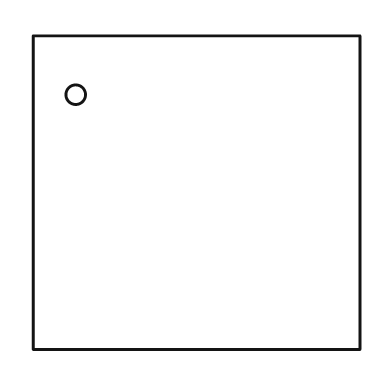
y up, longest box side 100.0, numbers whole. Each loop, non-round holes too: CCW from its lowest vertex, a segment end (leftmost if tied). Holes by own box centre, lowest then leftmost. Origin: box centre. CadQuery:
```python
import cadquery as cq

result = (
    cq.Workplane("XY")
    .moveTo(-50.0, -48.0)
    .lineTo(50.0, -48.0)
    .lineTo(50.0, 48.0)
    .lineTo(-50.0, 48.0)
    .close()
    .moveTo(-37.0, 30.0)
    .circle(3.0)
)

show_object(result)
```